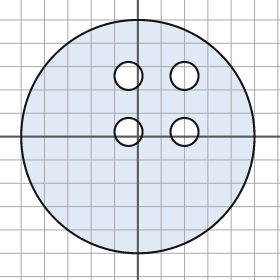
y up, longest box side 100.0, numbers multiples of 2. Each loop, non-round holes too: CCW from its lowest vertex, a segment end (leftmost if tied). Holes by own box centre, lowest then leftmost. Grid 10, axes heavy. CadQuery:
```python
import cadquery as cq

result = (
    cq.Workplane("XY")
    .moveTo(0.0, 0.0)
    .circle(50.0)
    .moveTo(-4.0, 2.0)
    .circle(6.0)
    .moveTo(20.0, 2.0)
    .circle(6.0)
    .moveTo(-4.0, 26.0)
    .circle(6.0)
    .moveTo(20.0, 26.0)
    .circle(6.0)
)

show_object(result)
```